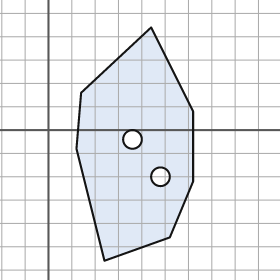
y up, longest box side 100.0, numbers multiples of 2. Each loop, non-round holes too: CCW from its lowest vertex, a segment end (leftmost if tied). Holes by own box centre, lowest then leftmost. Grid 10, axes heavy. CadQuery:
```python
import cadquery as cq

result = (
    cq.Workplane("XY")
    .moveTo(24.0, -56.0)
    .lineTo(52.0, -46.0)
    .lineTo(62.0, -22.0)
    .lineTo(62.0, 8.0)
    .lineTo(44.0, 44.0)
    .lineTo(14.0, 16.0)
    .lineTo(12.0, -8.0)
    .close()
    .moveTo(48.0, -20.0)
    .circle(4.0)
    .moveTo(36.0, -4.0)
    .circle(4.0)
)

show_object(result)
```